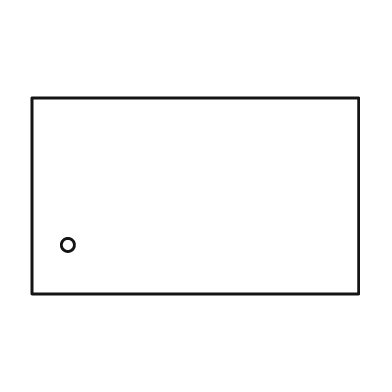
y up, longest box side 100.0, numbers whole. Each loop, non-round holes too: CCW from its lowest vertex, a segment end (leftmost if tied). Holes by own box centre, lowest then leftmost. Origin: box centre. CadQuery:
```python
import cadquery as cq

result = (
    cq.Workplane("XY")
    .moveTo(-50.0, -30.0)
    .lineTo(50.0, -30.0)
    .lineTo(50.0, 30.0)
    .lineTo(-50.0, 30.0)
    .close()
    .moveTo(-39.0, -15.0)
    .circle(2.0)
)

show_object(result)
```